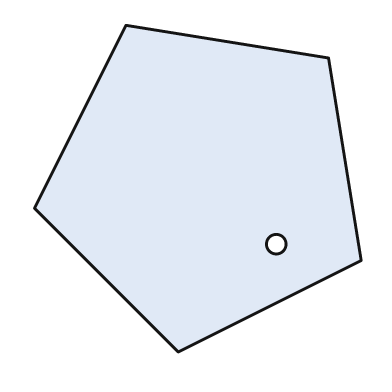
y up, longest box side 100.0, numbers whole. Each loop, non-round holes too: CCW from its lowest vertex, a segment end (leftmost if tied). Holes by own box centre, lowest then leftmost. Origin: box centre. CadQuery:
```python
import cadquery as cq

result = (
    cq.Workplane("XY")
    .moveTo(-6.0, -50.0)
    .lineTo(50.0, -22.0)
    .lineTo(40.0, 40.0)
    .lineTo(-22.0, 50.0)
    .lineTo(-50.0, -6.0)
    .close()
    .moveTo(24.0, -17.0)
    .circle(3.0)
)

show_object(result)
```